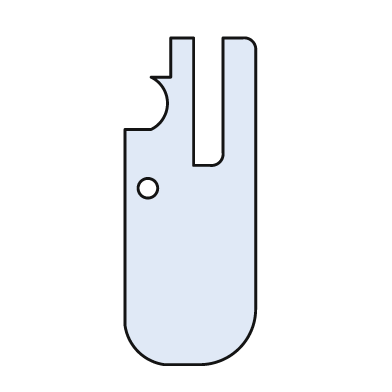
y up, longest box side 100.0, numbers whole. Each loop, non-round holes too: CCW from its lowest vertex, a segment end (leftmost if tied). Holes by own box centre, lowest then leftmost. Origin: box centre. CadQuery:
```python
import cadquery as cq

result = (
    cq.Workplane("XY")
    .moveTo(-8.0, -50.0)
    .lineTo(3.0, -50.0)
    .threePointArc((15.0, -45.0), (20.0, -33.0))
    .lineTo(20.0, 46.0)
    .threePointArc((19.0, 49.0), (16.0, 50.0))
    .lineTo(10.0, 50.0)
    .lineTo(10.0, 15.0)
    .threePointArc((9.0, 12.0), (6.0, 11.0))
    .lineTo(1.0, 11.0)
    .lineTo(1.0, 50.0)
    .lineTo(-6.0, 50.0)
    .lineTo(-6.0, 38.0)
    .lineTo(-12.0, 38.0)
    .threePointArc((-7.0, 30.0), (-12.0, 22.0))
    .lineTo(-20.0, 22.0)
    .lineTo(-20.0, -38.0)
    .threePointArc((-16.0, -46.0), (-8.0, -50.0))
    .close()
    .moveTo(-13.0, 4.0)
    .circle(3.0)
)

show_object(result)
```